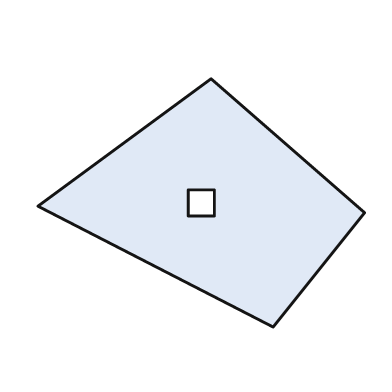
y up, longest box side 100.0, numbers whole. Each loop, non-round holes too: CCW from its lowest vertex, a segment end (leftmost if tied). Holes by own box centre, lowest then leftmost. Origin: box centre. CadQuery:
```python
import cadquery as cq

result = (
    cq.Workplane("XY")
    .moveTo(22.0, -38.0)
    .lineTo(50.0, -3.0)
    .lineTo(3.0, 38.0)
    .lineTo(-50.0, -1.0)
    .close()
    .moveTo(-4.0, -4.0)
    .lineTo(4.0, -4.0)
    .lineTo(4.0, 4.0)
    .lineTo(-4.0, 4.0)
    .close()
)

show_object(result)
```